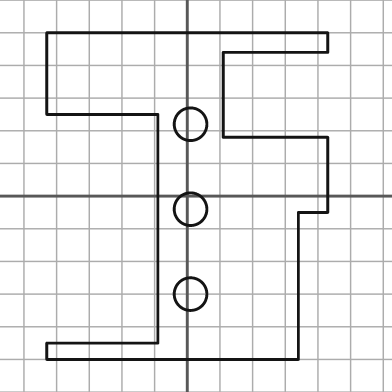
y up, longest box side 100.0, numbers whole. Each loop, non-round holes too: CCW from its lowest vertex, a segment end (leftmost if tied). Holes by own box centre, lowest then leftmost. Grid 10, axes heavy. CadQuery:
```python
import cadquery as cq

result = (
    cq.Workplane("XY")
    .moveTo(-43.0, -50.0)
    .lineTo(34.0, -50.0)
    .lineTo(34.0, -5.0)
    .lineTo(43.0, -5.0)
    .lineTo(43.0, 18.0)
    .lineTo(11.0, 18.0)
    .lineTo(11.0, 44.0)
    .lineTo(43.0, 44.0)
    .lineTo(43.0, 50.0)
    .lineTo(-43.0, 50.0)
    .lineTo(-43.0, 25.0)
    .lineTo(-9.0, 25.0)
    .lineTo(-9.0, -45.0)
    .lineTo(-43.0, -45.0)
    .close()
    .moveTo(1.0, -30.0)
    .circle(5.0)
    .moveTo(1.0, -4.0)
    .circle(5.0)
    .moveTo(1.0, 22.0)
    .circle(5.0)
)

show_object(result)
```